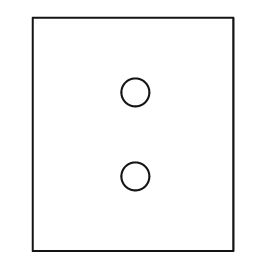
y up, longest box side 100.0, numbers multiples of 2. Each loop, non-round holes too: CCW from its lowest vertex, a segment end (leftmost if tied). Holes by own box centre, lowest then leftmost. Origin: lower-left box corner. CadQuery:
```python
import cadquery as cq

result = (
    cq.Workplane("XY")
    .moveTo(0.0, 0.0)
    .lineTo(86.0, 0.0)
    .lineTo(86.0, 100.0)
    .lineTo(0.0, 100.0)
    .close()
    .moveTo(44.0, 32.0)
    .circle(6.0)
    .moveTo(44.0, 68.0)
    .circle(6.0)
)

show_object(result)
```